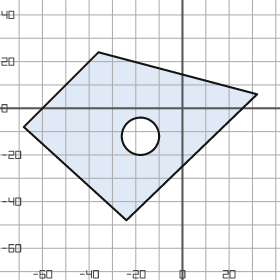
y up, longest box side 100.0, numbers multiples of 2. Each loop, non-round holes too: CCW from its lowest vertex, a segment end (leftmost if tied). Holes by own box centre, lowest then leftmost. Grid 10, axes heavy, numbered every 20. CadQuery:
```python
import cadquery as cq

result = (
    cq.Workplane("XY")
    .moveTo(-24.0, -48.0)
    .lineTo(32.0, 6.0)
    .lineTo(-36.0, 24.0)
    .lineTo(-68.0, -8.0)
    .close()
    .moveTo(-18.0, -12.0)
    .circle(8.0)
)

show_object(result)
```